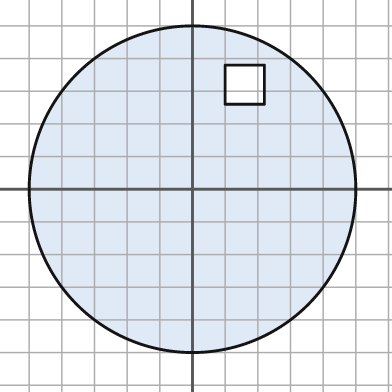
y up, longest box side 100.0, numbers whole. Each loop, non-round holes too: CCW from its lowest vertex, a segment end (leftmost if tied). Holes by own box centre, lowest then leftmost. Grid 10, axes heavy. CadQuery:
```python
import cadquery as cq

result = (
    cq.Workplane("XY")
    .moveTo(0.0, 0.0)
    .circle(50.0)
    .moveTo(10.0, 26.0)
    .lineTo(22.0, 26.0)
    .lineTo(22.0, 38.0)
    .lineTo(10.0, 38.0)
    .close()
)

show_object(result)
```